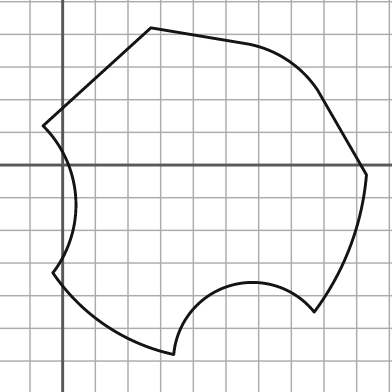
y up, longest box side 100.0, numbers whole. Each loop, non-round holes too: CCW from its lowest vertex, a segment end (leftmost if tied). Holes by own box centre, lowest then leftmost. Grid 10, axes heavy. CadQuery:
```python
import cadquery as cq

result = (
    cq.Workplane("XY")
    .moveTo(34.0, -58.0)
    .threePointArc((51.0, -37.0), (77.0, -45.0))
    .threePointArc((88.0, -25.0), (93.0, -3.0))
    .lineTo(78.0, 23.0)
    .threePointArc((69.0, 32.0), (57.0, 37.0))
    .lineTo(27.0, 42.0)
    .lineTo(-6.0, 12.0)
    .threePointArc((4.0, -10.0), (-3.0, -33.0))
    .threePointArc((13.0, -49.0), (34.0, -58.0))
    .close()
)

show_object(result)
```